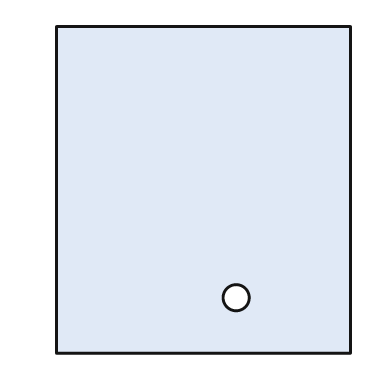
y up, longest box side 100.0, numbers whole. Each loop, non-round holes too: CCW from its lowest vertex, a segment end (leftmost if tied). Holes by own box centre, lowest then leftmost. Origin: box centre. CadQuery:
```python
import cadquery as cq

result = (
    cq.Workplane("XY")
    .moveTo(-45.0, -50.0)
    .lineTo(45.0, -50.0)
    .lineTo(45.0, 50.0)
    .lineTo(-45.0, 50.0)
    .close()
    .moveTo(10.0, -33.0)
    .circle(4.0)
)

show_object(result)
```